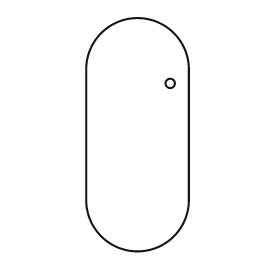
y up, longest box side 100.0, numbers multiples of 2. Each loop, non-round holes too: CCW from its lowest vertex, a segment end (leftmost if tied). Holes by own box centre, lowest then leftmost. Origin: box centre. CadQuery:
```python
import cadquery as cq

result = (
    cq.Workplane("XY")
    .moveTo(-22.0, -28.0)
    .threePointArc((0.0, -50.0), (22.0, -28.0))
    .lineTo(22.0, 28.0)
    .threePointArc((0.0, 50.0), (-22.0, 28.0))
    .close()
    .moveTo(14.0, 22.0)
    .circle(2.0)
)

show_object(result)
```